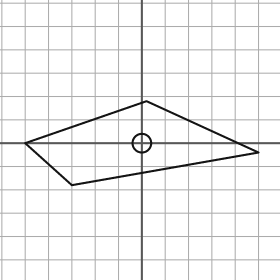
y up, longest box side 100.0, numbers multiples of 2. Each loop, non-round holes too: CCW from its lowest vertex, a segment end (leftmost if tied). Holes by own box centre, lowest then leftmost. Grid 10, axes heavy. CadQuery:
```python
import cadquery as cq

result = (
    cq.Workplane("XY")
    .moveTo(-30.0, -18.0)
    .lineTo(50.0, -4.0)
    .lineTo(2.0, 18.0)
    .lineTo(-50.0, 0.0)
    .close()
    .moveTo(0.0, 0.0)
    .circle(4.0)
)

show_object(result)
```